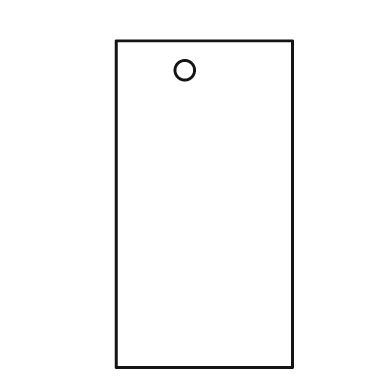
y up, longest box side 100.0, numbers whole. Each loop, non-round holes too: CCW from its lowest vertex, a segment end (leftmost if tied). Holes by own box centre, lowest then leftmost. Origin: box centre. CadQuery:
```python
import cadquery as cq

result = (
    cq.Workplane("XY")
    .moveTo(-27.0, -50.0)
    .lineTo(27.0, -50.0)
    .lineTo(27.0, 50.0)
    .lineTo(-27.0, 50.0)
    .close()
    .moveTo(-6.0, 41.0)
    .circle(3.0)
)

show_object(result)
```